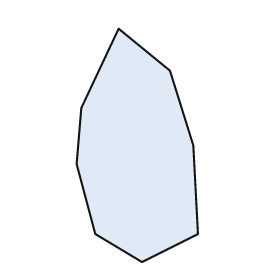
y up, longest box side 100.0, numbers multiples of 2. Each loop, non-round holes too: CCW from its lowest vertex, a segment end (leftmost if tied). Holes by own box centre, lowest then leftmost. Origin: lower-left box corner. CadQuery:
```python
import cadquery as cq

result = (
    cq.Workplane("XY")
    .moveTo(28.0, 0.0)
    .lineTo(52.0, 12.0)
    .lineTo(50.0, 50.0)
    .lineTo(40.0, 82.0)
    .lineTo(18.0, 100.0)
    .lineTo(2.0, 66.0)
    .lineTo(0.0, 42.0)
    .lineTo(8.0, 12.0)
    .close()
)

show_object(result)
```